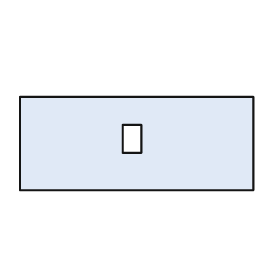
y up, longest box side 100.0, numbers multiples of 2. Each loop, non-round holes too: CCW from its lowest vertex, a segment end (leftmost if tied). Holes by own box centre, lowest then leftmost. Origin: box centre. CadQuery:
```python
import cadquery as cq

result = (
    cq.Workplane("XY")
    .moveTo(-50.0, -20.0)
    .lineTo(50.0, -20.0)
    .lineTo(50.0, 20.0)
    .lineTo(-50.0, 20.0)
    .close()
    .moveTo(-6.0, -4.0)
    .lineTo(2.0, -4.0)
    .lineTo(2.0, 8.0)
    .lineTo(-6.0, 8.0)
    .close()
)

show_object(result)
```